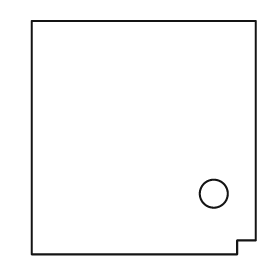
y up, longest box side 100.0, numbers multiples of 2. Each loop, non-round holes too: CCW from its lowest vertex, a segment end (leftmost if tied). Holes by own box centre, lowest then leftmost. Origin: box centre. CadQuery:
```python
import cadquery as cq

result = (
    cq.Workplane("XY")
    .moveTo(-48.0, -50.0)
    .lineTo(40.0, -50.0)
    .lineTo(40.0, -44.0)
    .lineTo(48.0, -44.0)
    .lineTo(48.0, 50.0)
    .lineTo(-48.0, 50.0)
    .close()
    .moveTo(30.0, -24.0)
    .circle(6.0)
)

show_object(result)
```